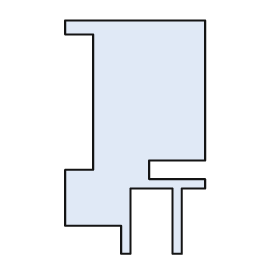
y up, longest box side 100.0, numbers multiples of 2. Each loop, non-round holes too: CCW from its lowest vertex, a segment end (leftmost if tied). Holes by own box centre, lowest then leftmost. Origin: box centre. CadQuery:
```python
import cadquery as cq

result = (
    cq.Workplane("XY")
    .moveTo(-6.0, -50.0)
    .lineTo(-2.0, -50.0)
    .lineTo(-2.0, -22.0)
    .lineTo(16.0, -22.0)
    .lineTo(16.0, -50.0)
    .lineTo(20.0, -50.0)
    .lineTo(20.0, -22.0)
    .lineTo(30.0, -22.0)
    .lineTo(30.0, -18.0)
    .lineTo(6.0, -18.0)
    .lineTo(6.0, -10.0)
    .lineTo(30.0, -10.0)
    .lineTo(30.0, 50.0)
    .lineTo(-30.0, 50.0)
    .lineTo(-30.0, 44.0)
    .lineTo(-18.0, 44.0)
    .lineTo(-18.0, -14.0)
    .lineTo(-30.0, -14.0)
    .lineTo(-30.0, -38.0)
    .lineTo(-6.0, -38.0)
    .close()
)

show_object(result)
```